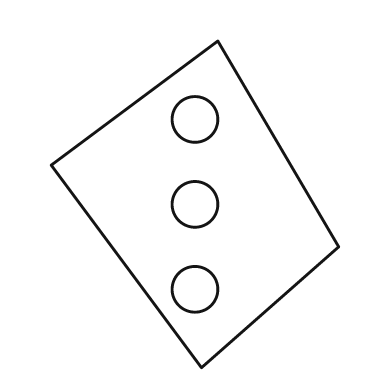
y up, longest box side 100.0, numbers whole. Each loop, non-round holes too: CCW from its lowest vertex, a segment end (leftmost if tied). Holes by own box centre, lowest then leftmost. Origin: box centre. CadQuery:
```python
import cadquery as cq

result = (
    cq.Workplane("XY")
    .moveTo(2.0, -50.0)
    .lineTo(44.0, -13.0)
    .lineTo(7.0, 50.0)
    .lineTo(-44.0, 12.0)
    .close()
    .moveTo(0.0, -26.0)
    .circle(7.0)
    .moveTo(0.0, 0.0)
    .circle(7.0)
    .moveTo(0.0, 26.0)
    .circle(7.0)
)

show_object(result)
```